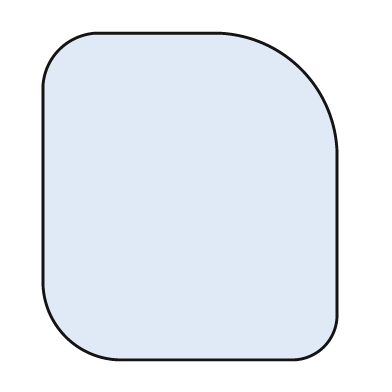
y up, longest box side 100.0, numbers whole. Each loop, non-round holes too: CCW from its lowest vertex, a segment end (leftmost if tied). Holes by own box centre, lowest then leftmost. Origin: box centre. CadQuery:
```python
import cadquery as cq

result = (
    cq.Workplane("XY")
    .moveTo(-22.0, -50.0)
    .lineTo(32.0, -50.0)
    .threePointArc((41.0, -46.0), (45.0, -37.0))
    .lineTo(45.0, 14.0)
    .threePointArc((34.0, 39.0), (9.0, 50.0))
    .lineTo(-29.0, 50.0)
    .threePointArc((-40.0, 45.0), (-45.0, 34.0))
    .lineTo(-45.0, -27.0)
    .threePointArc((-38.0, -43.0), (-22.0, -50.0))
    .close()
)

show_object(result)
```